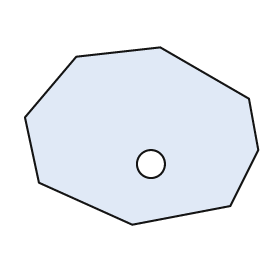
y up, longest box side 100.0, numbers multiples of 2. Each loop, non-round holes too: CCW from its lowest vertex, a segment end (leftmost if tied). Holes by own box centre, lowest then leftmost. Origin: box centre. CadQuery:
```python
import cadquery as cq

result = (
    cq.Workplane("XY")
    .moveTo(-4.0, -38.0)
    .lineTo(38.0, -30.0)
    .lineTo(50.0, -6.0)
    .lineTo(46.0, 16.0)
    .lineTo(8.0, 38.0)
    .lineTo(-28.0, 34.0)
    .lineTo(-50.0, 8.0)
    .lineTo(-44.0, -20.0)
    .close()
    .moveTo(4.0, -12.0)
    .circle(6.0)
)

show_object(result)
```